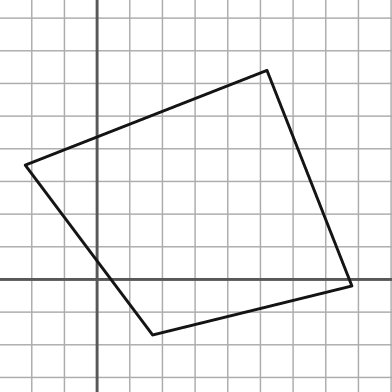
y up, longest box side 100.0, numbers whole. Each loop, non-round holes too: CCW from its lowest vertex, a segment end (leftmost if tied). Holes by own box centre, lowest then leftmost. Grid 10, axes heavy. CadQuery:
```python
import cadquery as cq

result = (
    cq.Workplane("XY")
    .moveTo(17.0, -17.0)
    .lineTo(78.0, -2.0)
    .lineTo(52.0, 64.0)
    .lineTo(-22.0, 35.0)
    .close()
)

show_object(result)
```